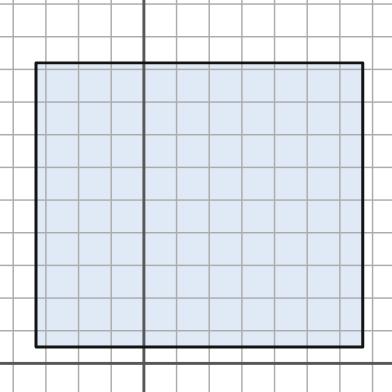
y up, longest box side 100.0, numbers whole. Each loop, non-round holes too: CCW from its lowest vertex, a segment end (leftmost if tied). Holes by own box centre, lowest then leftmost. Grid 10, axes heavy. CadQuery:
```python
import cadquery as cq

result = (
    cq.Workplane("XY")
    .moveTo(-33.0, 5.0)
    .lineTo(67.0, 5.0)
    .lineTo(67.0, 92.0)
    .lineTo(-33.0, 92.0)
    .close()
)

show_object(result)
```